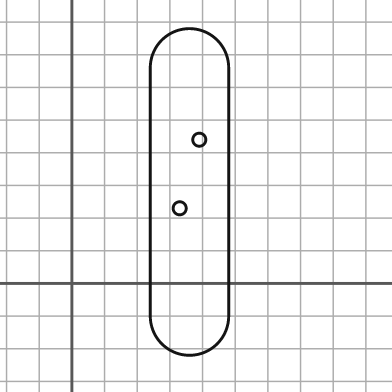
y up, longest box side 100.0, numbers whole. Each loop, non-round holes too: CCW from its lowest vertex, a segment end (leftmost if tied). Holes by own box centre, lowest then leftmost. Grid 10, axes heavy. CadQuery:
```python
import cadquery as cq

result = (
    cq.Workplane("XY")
    .moveTo(24.0, -10.0)
    .threePointArc((36.0, -22.0), (48.0, -10.0))
    .lineTo(48.0, 66.0)
    .threePointArc((36.0, 78.0), (24.0, 66.0))
    .close()
    .moveTo(33.0, 23.0)
    .circle(2.0)
    .moveTo(39.0, 44.0)
    .circle(2.0)
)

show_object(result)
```